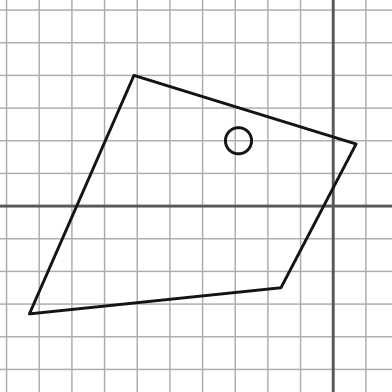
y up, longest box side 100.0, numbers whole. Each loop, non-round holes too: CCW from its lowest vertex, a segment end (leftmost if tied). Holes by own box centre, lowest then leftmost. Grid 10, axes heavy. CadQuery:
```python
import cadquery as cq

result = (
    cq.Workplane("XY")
    .moveTo(-93.0, -33.0)
    .lineTo(-16.0, -25.0)
    .lineTo(7.0, 19.0)
    .lineTo(-61.0, 40.0)
    .close()
    .moveTo(-29.0, 20.0)
    .circle(4.0)
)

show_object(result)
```